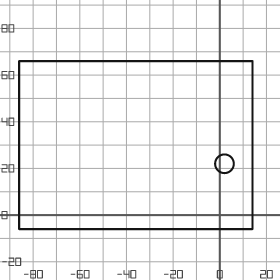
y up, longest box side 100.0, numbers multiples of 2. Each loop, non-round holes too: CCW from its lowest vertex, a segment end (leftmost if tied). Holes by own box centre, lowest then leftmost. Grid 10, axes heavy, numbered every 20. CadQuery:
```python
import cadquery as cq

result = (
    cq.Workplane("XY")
    .moveTo(-86.0, -6.0)
    .lineTo(14.0, -6.0)
    .lineTo(14.0, 66.0)
    .lineTo(-86.0, 66.0)
    .close()
    .moveTo(2.0, 22.0)
    .circle(4.0)
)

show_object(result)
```